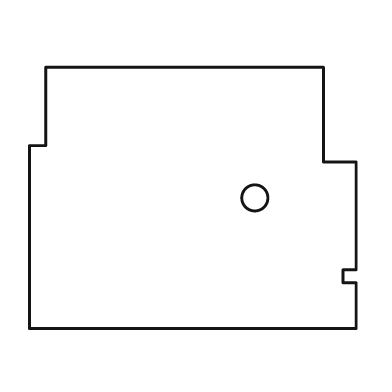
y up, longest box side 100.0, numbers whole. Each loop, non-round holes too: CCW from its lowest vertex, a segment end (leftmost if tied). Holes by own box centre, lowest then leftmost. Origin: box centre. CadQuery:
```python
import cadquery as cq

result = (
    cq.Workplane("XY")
    .moveTo(-50.0, -40.0)
    .lineTo(50.0, -40.0)
    .lineTo(50.0, -26.0)
    .lineTo(46.0, -26.0)
    .lineTo(46.0, -22.0)
    .lineTo(50.0, -22.0)
    .lineTo(50.0, 11.0)
    .lineTo(40.0, 11.0)
    .lineTo(40.0, 40.0)
    .lineTo(-45.0, 40.0)
    .lineTo(-45.0, 16.0)
    .lineTo(-50.0, 16.0)
    .close()
    .moveTo(19.0, 0.0)
    .circle(4.0)
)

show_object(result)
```